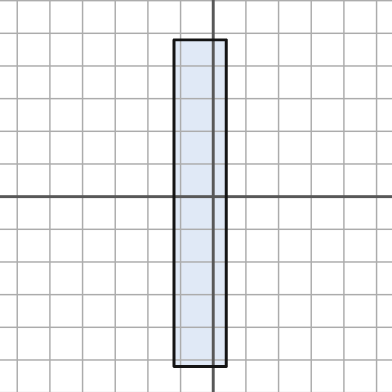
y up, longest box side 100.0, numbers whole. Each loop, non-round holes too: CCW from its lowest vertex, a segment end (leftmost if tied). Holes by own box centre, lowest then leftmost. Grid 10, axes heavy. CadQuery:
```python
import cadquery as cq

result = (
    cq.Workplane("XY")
    .moveTo(-12.0, -52.0)
    .lineTo(4.0, -52.0)
    .lineTo(4.0, 48.0)
    .lineTo(-12.0, 48.0)
    .close()
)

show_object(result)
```